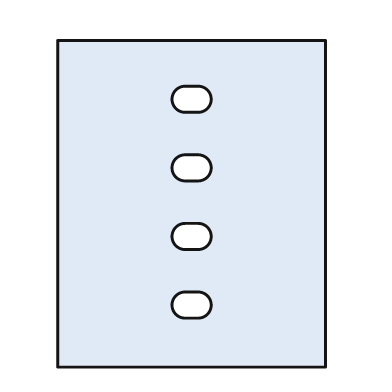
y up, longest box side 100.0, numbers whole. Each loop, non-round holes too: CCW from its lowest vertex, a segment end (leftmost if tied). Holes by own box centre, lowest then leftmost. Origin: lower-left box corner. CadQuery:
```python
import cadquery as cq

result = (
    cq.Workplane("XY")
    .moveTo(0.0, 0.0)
    .lineTo(82.0, 0.0)
    .lineTo(82.0, 100.0)
    .lineTo(0.0, 100.0)
    .close()
    .moveTo(39.0, 15.0)
    .lineTo(43.0, 15.0)
    .threePointArc((47.0, 19.0), (43.0, 23.0))
    .lineTo(39.0, 23.0)
    .threePointArc((35.0, 19.0), (39.0, 15.0))
    .close()
    .moveTo(39.0, 36.0)
    .lineTo(43.0, 36.0)
    .threePointArc((47.0, 40.0), (43.0, 44.0))
    .lineTo(39.0, 44.0)
    .threePointArc((35.0, 40.0), (39.0, 36.0))
    .close()
    .moveTo(39.0, 57.0)
    .lineTo(43.0, 57.0)
    .threePointArc((47.0, 61.0), (43.0, 65.0))
    .lineTo(39.0, 65.0)
    .threePointArc((35.0, 61.0), (39.0, 57.0))
    .close()
    .moveTo(39.0, 78.0)
    .lineTo(43.0, 78.0)
    .threePointArc((47.0, 82.0), (43.0, 86.0))
    .lineTo(39.0, 86.0)
    .threePointArc((35.0, 82.0), (39.0, 78.0))
    .close()
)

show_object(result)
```